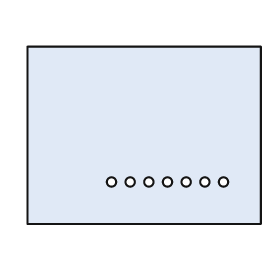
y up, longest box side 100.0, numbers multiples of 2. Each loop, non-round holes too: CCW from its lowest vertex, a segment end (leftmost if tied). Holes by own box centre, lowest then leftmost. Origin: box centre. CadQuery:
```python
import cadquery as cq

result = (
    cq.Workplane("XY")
    .moveTo(-50.0, -38.0)
    .lineTo(50.0, -38.0)
    .lineTo(50.0, 38.0)
    .lineTo(-50.0, 38.0)
    .close()
    .moveTo(-14.0, -20.0)
    .circle(2.0)
    .moveTo(-6.0, -20.0)
    .circle(2.0)
    .moveTo(2.0, -20.0)
    .circle(2.0)
    .moveTo(10.0, -20.0)
    .circle(2.0)
    .moveTo(18.0, -20.0)
    .circle(2.0)
    .moveTo(26.0, -20.0)
    .circle(2.0)
    .moveTo(34.0, -20.0)
    .circle(2.0)
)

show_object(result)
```